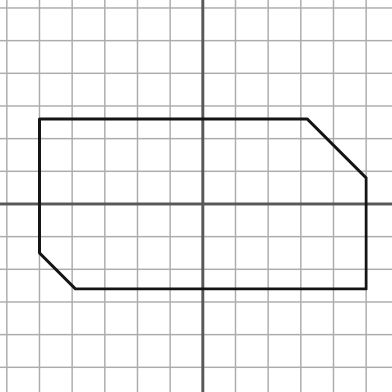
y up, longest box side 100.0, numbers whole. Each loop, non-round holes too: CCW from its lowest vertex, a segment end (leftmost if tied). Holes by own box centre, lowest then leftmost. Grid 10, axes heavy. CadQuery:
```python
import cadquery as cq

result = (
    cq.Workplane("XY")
    .moveTo(-39.0, -26.0)
    .lineTo(50.0, -26.0)
    .lineTo(50.0, 8.0)
    .lineTo(32.0, 26.0)
    .lineTo(-50.0, 26.0)
    .lineTo(-50.0, -15.0)
    .close()
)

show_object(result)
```